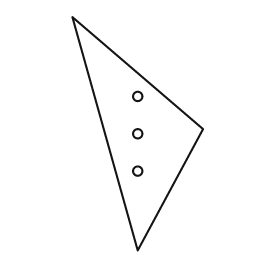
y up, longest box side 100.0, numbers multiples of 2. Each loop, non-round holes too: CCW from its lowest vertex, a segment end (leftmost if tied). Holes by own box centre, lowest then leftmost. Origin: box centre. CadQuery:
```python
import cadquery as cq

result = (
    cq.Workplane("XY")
    .moveTo(0.0, -50.0)
    .lineTo(28.0, 2.0)
    .lineTo(-28.0, 50.0)
    .close()
    .moveTo(0.0, -16.0)
    .circle(2.0)
    .moveTo(0.0, 0.0)
    .circle(2.0)
    .moveTo(0.0, 16.0)
    .circle(2.0)
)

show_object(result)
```